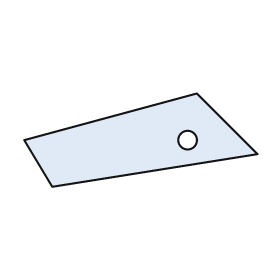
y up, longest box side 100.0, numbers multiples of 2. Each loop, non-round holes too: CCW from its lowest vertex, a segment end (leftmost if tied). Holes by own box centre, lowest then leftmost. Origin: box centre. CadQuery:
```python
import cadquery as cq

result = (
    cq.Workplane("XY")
    .moveTo(-38.0, -20.0)
    .lineTo(50.0, -6.0)
    .lineTo(24.0, 20.0)
    .lineTo(-50.0, 0.0)
    .close()
    .moveTo(20.0, 0.0)
    .circle(4.0)
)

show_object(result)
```